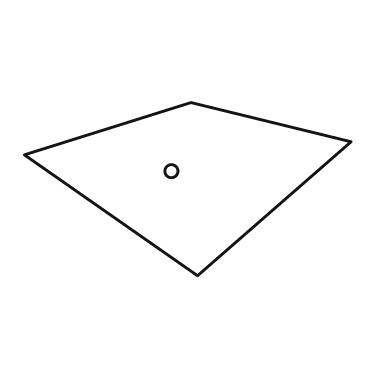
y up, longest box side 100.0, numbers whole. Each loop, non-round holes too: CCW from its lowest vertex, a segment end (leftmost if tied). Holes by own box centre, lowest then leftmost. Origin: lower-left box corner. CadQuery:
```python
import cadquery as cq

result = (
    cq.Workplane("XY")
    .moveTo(53.0, 0.0)
    .lineTo(100.0, 41.0)
    .lineTo(51.0, 53.0)
    .lineTo(0.0, 37.0)
    .close()
    .moveTo(45.0, 32.0)
    .circle(2.0)
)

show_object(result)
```